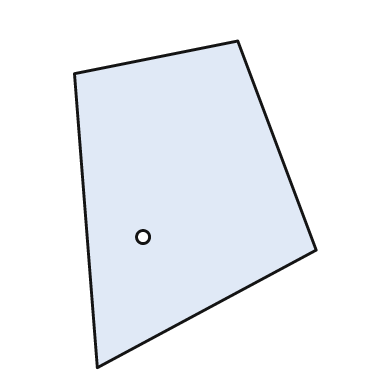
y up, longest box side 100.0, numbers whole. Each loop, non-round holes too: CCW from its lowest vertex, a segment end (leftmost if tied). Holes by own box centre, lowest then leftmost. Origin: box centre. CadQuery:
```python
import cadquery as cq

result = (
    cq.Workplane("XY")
    .moveTo(-30.0, -50.0)
    .lineTo(37.0, -14.0)
    .lineTo(13.0, 50.0)
    .lineTo(-37.0, 40.0)
    .close()
    .moveTo(-16.0, -10.0)
    .circle(2.0)
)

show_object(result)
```